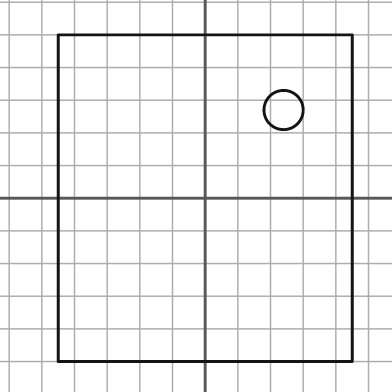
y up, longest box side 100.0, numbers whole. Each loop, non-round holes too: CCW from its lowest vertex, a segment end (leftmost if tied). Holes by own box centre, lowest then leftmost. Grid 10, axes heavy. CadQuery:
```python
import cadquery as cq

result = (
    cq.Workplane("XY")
    .moveTo(-45.0, -50.0)
    .lineTo(45.0, -50.0)
    .lineTo(45.0, 50.0)
    .lineTo(-45.0, 50.0)
    .close()
    .moveTo(24.0, 27.0)
    .circle(6.0)
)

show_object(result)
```